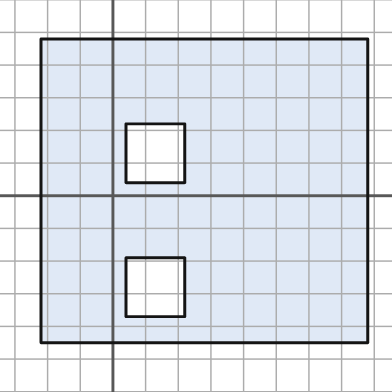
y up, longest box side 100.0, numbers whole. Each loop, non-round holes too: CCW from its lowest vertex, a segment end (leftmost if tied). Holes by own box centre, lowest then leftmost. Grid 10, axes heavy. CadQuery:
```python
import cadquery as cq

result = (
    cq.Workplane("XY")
    .moveTo(-22.0, -45.0)
    .lineTo(78.0, -45.0)
    .lineTo(78.0, 48.0)
    .lineTo(-22.0, 48.0)
    .close()
    .moveTo(4.0, -37.0)
    .lineTo(22.0, -37.0)
    .lineTo(22.0, -19.0)
    .lineTo(4.0, -19.0)
    .close()
    .moveTo(4.0, 4.0)
    .lineTo(22.0, 4.0)
    .lineTo(22.0, 22.0)
    .lineTo(4.0, 22.0)
    .close()
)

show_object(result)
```